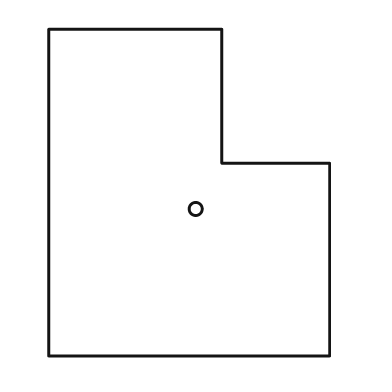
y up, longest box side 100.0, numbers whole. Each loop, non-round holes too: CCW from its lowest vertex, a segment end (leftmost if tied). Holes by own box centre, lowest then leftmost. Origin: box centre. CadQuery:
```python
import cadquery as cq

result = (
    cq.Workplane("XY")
    .moveTo(-43.0, -50.0)
    .lineTo(43.0, -50.0)
    .lineTo(43.0, 9.0)
    .lineTo(10.0, 9.0)
    .lineTo(10.0, 50.0)
    .lineTo(-43.0, 50.0)
    .close()
    .moveTo(2.0, -5.0)
    .circle(2.0)
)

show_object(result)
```